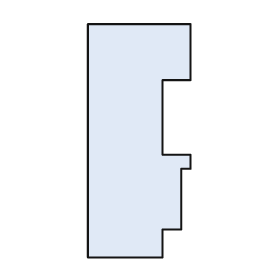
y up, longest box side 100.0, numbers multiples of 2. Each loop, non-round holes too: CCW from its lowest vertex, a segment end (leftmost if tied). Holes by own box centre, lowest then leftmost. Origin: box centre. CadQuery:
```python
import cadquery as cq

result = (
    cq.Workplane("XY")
    .moveTo(-22.0, -50.0)
    .lineTo(10.0, -50.0)
    .lineTo(10.0, -38.0)
    .lineTo(18.0, -38.0)
    .lineTo(18.0, -12.0)
    .lineTo(22.0, -12.0)
    .lineTo(22.0, -6.0)
    .lineTo(10.0, -6.0)
    .lineTo(10.0, 26.0)
    .lineTo(22.0, 26.0)
    .lineTo(22.0, 50.0)
    .lineTo(-22.0, 50.0)
    .close()
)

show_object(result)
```